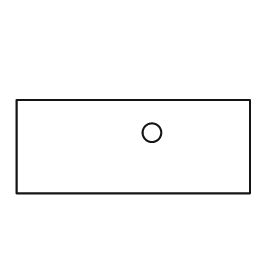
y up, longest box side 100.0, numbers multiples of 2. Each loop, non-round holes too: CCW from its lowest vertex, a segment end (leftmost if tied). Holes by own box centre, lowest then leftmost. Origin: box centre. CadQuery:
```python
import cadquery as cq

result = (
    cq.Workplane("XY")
    .moveTo(-50.0, -20.0)
    .lineTo(50.0, -20.0)
    .lineTo(50.0, 20.0)
    .lineTo(-50.0, 20.0)
    .close()
    .moveTo(8.0, 6.0)
    .circle(4.0)
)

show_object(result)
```